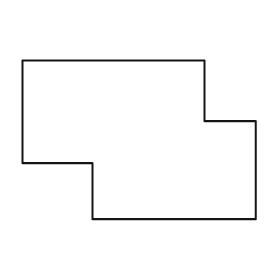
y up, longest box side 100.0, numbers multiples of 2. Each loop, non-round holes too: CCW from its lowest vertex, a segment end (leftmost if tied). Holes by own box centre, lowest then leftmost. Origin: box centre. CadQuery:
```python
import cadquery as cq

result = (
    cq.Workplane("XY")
    .moveTo(-20.0, -34.0)
    .lineTo(50.0, -34.0)
    .lineTo(50.0, 8.0)
    .lineTo(28.0, 8.0)
    .lineTo(28.0, 34.0)
    .lineTo(-50.0, 34.0)
    .lineTo(-50.0, -10.0)
    .lineTo(-20.0, -10.0)
    .close()
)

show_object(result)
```